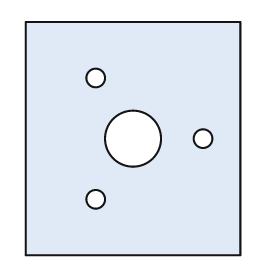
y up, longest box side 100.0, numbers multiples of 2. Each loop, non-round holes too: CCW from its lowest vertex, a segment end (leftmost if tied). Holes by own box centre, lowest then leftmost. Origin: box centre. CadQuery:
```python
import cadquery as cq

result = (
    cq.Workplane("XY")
    .moveTo(-46.0, -50.0)
    .lineTo(46.0, -50.0)
    .lineTo(46.0, 50.0)
    .lineTo(-46.0, 50.0)
    .close()
    .moveTo(-16.0, -26.0)
    .circle(4.0)
    .moveTo(0.0, 0.0)
    .circle(12.0)
    .moveTo(30.0, 0.0)
    .circle(4.0)
    .moveTo(-16.0, 26.0)
    .circle(4.0)
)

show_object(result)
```